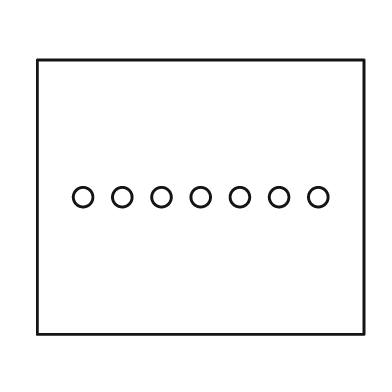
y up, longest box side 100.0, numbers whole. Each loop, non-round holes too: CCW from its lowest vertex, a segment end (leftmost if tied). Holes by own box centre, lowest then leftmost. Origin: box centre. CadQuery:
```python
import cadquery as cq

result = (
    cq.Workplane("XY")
    .moveTo(-50.0, -42.0)
    .lineTo(50.0, -42.0)
    .lineTo(50.0, 42.0)
    .lineTo(-50.0, 42.0)
    .close()
    .moveTo(-36.0, 0.0)
    .circle(3.0)
    .moveTo(-24.0, 0.0)
    .circle(3.0)
    .moveTo(-12.0, 0.0)
    .circle(3.0)
    .moveTo(0.0, 0.0)
    .circle(3.0)
    .moveTo(12.0, 0.0)
    .circle(3.0)
    .moveTo(24.0, 0.0)
    .circle(3.0)
    .moveTo(36.0, 0.0)
    .circle(3.0)
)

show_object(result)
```